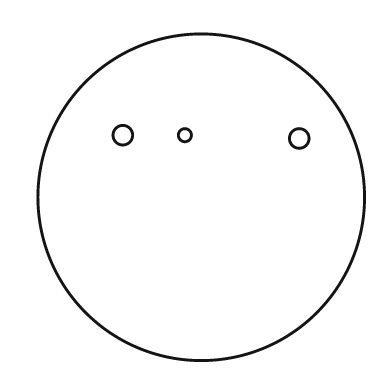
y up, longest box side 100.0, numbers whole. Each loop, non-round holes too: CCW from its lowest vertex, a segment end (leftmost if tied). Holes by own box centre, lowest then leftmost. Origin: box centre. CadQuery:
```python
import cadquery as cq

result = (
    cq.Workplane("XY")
    .moveTo(0.0, 0.0)
    .circle(50.0)
    .moveTo(30.0, 18.0)
    .circle(3.0)
    .moveTo(-24.0, 19.0)
    .circle(3.0)
    .moveTo(-5.0, 19.0)
    .circle(2.0)
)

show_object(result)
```